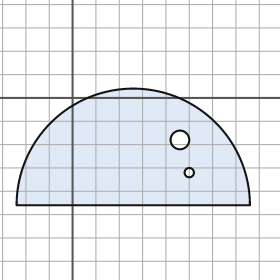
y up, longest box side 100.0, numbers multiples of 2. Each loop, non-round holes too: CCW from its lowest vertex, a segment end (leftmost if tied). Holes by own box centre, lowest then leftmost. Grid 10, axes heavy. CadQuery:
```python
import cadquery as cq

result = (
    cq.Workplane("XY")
    .moveTo(-24.0, -46.0)
    .lineTo(76.0, -46.0)
    .threePointArc((26.0, 4.0), (-24.0, -46.0))
    .close()
    .moveTo(50.0, -32.0)
    .circle(2.0)
    .moveTo(46.0, -18.0)
    .circle(4.0)
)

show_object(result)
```